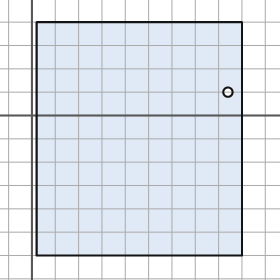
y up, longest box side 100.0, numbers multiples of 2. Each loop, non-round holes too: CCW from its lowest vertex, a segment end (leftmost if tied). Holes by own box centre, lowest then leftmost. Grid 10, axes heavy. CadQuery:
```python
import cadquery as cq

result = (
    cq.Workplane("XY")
    .moveTo(2.0, -60.0)
    .lineTo(90.0, -60.0)
    .lineTo(90.0, 40.0)
    .lineTo(2.0, 40.0)
    .close()
    .moveTo(84.0, 10.0)
    .circle(2.0)
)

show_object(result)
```